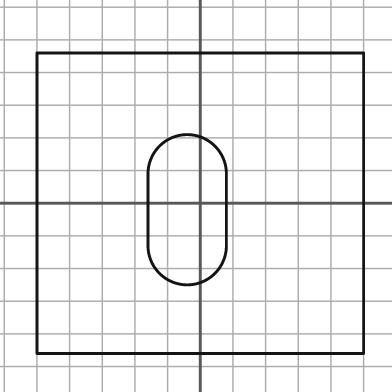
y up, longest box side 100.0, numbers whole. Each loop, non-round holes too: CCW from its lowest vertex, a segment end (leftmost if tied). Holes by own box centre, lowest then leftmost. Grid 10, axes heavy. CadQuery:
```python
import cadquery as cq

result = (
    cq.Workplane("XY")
    .moveTo(-50.0, -46.0)
    .lineTo(50.0, -46.0)
    .lineTo(50.0, 46.0)
    .lineTo(-50.0, 46.0)
    .close()
    .moveTo(-16.0, -13.0)
    .threePointArc((-4.0, -25.0), (8.0, -13.0))
    .lineTo(8.0, 9.0)
    .threePointArc((-4.0, 21.0), (-16.0, 9.0))
    .close()
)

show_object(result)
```